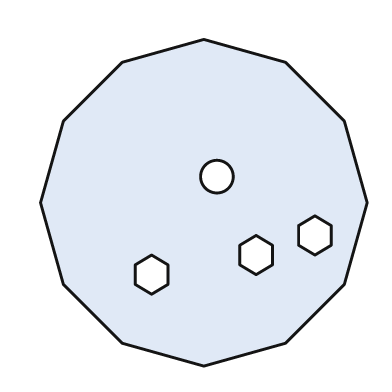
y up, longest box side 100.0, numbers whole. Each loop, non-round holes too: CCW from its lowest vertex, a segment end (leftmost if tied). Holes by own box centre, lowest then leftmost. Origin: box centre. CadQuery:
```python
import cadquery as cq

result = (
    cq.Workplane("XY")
    .moveTo(0.0, -50.0)
    .lineTo(25.0, -43.0)
    .lineTo(43.0, -25.0)
    .lineTo(50.0, 0.0)
    .lineTo(43.0, 25.0)
    .lineTo(25.0, 43.0)
    .lineTo(0.0, 50.0)
    .lineTo(-25.0, 43.0)
    .lineTo(-43.0, 25.0)
    .lineTo(-50.0, 0.0)
    .lineTo(-43.0, -25.0)
    .lineTo(-25.0, -43.0)
    .close()
    .moveTo(-16.0, -28.0)
    .lineTo(-11.0, -25.0)
    .lineTo(-11.0, -19.0)
    .lineTo(-16.0, -16.0)
    .lineTo(-21.0, -19.0)
    .lineTo(-21.0, -25.0)
    .close()
    .moveTo(16.0, -22.0)
    .lineTo(21.0, -19.0)
    .lineTo(21.0, -13.0)
    .lineTo(16.0, -10.0)
    .lineTo(11.0, -13.0)
    .lineTo(11.0, -19.0)
    .close()
    .moveTo(34.0, -16.0)
    .lineTo(39.0, -13.0)
    .lineTo(39.0, -7.0)
    .lineTo(34.0, -4.0)
    .lineTo(29.0, -7.0)
    .lineTo(29.0, -13.0)
    .close()
    .moveTo(4.0, 8.0)
    .circle(5.0)
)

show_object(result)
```